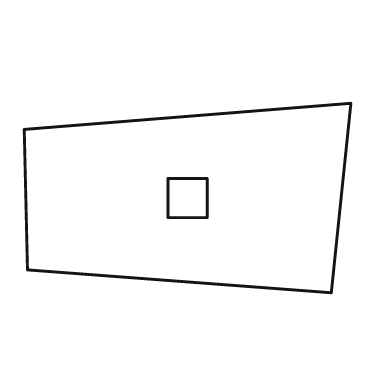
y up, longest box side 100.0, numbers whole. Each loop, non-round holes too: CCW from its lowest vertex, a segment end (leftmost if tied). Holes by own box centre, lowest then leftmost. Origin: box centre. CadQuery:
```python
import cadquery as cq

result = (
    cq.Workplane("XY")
    .moveTo(44.0, -29.0)
    .lineTo(50.0, 29.0)
    .lineTo(-50.0, 21.0)
    .lineTo(-49.0, -22.0)
    .close()
    .moveTo(-6.0, -6.0)
    .lineTo(6.0, -6.0)
    .lineTo(6.0, 6.0)
    .lineTo(-6.0, 6.0)
    .close()
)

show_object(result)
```